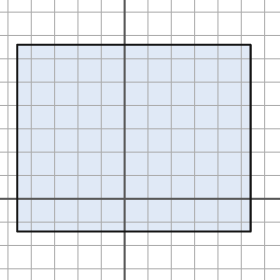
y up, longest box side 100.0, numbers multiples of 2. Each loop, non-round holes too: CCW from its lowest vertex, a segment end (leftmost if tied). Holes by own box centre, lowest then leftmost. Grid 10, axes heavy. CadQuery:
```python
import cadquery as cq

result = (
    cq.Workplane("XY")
    .moveTo(-46.0, -14.0)
    .lineTo(54.0, -14.0)
    .lineTo(54.0, 66.0)
    .lineTo(-46.0, 66.0)
    .close()
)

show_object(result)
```